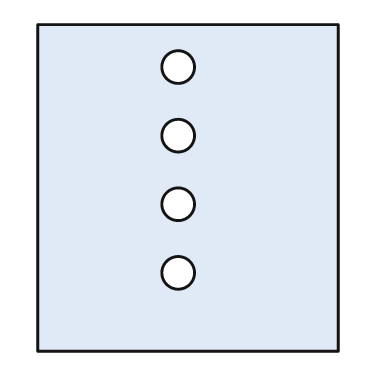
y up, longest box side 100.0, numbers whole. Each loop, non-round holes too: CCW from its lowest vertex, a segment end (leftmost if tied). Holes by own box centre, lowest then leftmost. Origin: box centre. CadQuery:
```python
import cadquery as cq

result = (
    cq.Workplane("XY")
    .moveTo(-46.0, -50.0)
    .lineTo(46.0, -50.0)
    .lineTo(46.0, 50.0)
    .lineTo(-46.0, 50.0)
    .close()
    .moveTo(-3.0, -26.0)
    .circle(5.0)
    .moveTo(-3.0, -5.0)
    .circle(5.0)
    .moveTo(-3.0, 16.0)
    .circle(5.0)
    .moveTo(-3.0, 37.0)
    .circle(5.0)
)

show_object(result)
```